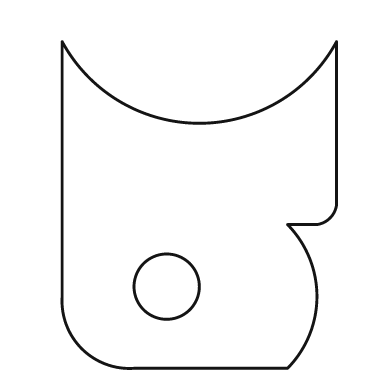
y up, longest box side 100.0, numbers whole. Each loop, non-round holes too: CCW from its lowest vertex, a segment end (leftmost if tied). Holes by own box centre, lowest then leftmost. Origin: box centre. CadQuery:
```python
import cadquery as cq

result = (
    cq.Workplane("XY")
    .moveTo(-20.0, -50.0)
    .lineTo(27.0, -50.0)
    .threePointArc((36.0, -28.0), (27.0, -6.0))
    .lineTo(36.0, -6.0)
    .threePointArc((40.0, -4.0), (42.0, 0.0))
    .lineTo(42.0, 50.0)
    .threePointArc((0.0, 25.0), (-42.0, 50.0))
    .lineTo(-42.0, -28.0)
    .threePointArc((-36.0, -44.0), (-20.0, -50.0))
    .close()
    .moveTo(-10.0, -25.0)
    .circle(10.0)
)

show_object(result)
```